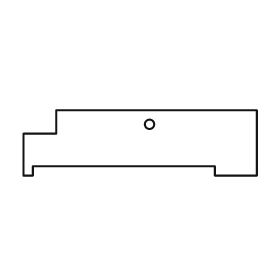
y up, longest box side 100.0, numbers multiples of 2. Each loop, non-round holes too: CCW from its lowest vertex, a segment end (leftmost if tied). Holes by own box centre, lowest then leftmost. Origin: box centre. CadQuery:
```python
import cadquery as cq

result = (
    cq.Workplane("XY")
    .moveTo(-50.0, -14.0)
    .lineTo(-46.0, -14.0)
    .lineTo(-46.0, -10.0)
    .lineTo(32.0, -10.0)
    .lineTo(32.0, -14.0)
    .lineTo(50.0, -14.0)
    .lineTo(50.0, 14.0)
    .lineTo(-36.0, 14.0)
    .lineTo(-36.0, 4.0)
    .lineTo(-50.0, 4.0)
    .close()
    .moveTo(4.0, 8.0)
    .circle(2.0)
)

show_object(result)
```